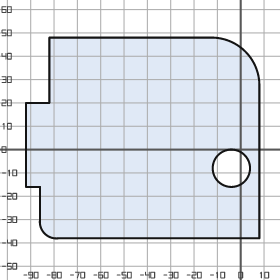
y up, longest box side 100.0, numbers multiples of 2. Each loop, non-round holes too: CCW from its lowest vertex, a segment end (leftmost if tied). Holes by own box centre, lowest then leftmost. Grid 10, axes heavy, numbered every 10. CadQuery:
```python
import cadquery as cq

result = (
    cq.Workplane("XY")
    .moveTo(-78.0, -38.0)
    .lineTo(8.0, -38.0)
    .lineTo(8.0, 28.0)
    .threePointArc((2.0, 42.0), (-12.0, 48.0))
    .lineTo(-82.0, 48.0)
    .lineTo(-82.0, 20.0)
    .lineTo(-92.0, 20.0)
    .lineTo(-92.0, -16.0)
    .lineTo(-86.0, -16.0)
    .lineTo(-86.0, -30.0)
    .threePointArc((-84.0, -36.0), (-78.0, -38.0))
    .close()
    .moveTo(-4.0, -8.0)
    .circle(8.0)
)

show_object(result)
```